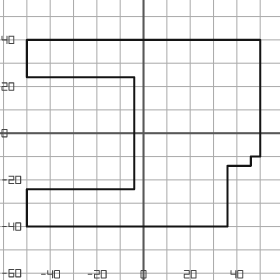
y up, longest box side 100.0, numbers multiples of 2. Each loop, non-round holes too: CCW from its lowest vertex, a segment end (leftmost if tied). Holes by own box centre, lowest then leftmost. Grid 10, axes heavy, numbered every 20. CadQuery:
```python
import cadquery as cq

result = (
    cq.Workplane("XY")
    .moveTo(-50.0, -40.0)
    .lineTo(36.0, -40.0)
    .lineTo(36.0, -14.0)
    .lineTo(46.0, -14.0)
    .lineTo(46.0, -10.0)
    .lineTo(50.0, -10.0)
    .lineTo(50.0, 40.0)
    .lineTo(-50.0, 40.0)
    .lineTo(-50.0, 24.0)
    .lineTo(-4.0, 24.0)
    .lineTo(-4.0, -24.0)
    .lineTo(-50.0, -24.0)
    .close()
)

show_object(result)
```